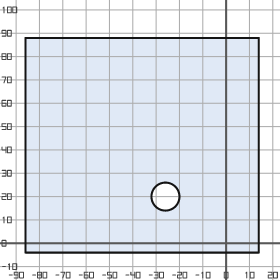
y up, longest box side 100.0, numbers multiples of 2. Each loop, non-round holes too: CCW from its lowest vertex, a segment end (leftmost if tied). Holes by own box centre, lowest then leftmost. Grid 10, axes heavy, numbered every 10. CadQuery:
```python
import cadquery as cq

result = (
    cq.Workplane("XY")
    .moveTo(-86.0, -4.0)
    .lineTo(14.0, -4.0)
    .lineTo(14.0, 88.0)
    .lineTo(-86.0, 88.0)
    .close()
    .moveTo(-26.0, 20.0)
    .circle(6.0)
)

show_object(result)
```